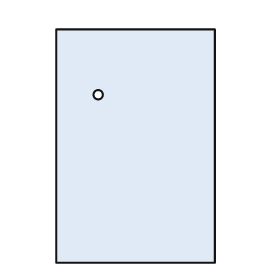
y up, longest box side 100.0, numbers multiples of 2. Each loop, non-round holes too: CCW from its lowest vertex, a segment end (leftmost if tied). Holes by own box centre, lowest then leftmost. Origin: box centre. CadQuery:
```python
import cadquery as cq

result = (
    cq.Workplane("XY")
    .moveTo(-34.0, -50.0)
    .lineTo(34.0, -50.0)
    .lineTo(34.0, 50.0)
    .lineTo(-34.0, 50.0)
    .close()
    .moveTo(-16.0, 22.0)
    .circle(2.0)
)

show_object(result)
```